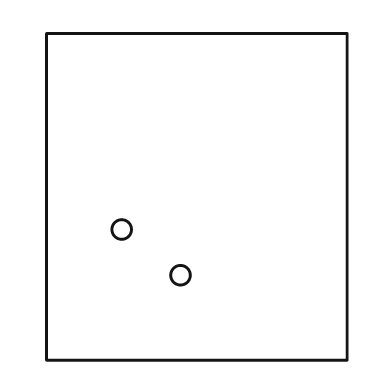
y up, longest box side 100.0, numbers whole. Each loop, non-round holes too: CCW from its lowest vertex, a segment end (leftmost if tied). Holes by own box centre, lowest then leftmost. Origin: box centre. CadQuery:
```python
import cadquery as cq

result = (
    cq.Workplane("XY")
    .moveTo(-46.0, -50.0)
    .lineTo(46.0, -50.0)
    .lineTo(46.0, 50.0)
    .lineTo(-46.0, 50.0)
    .close()
    .moveTo(-5.0, -24.0)
    .circle(3.0)
    .moveTo(-23.0, -10.0)
    .circle(3.0)
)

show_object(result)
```